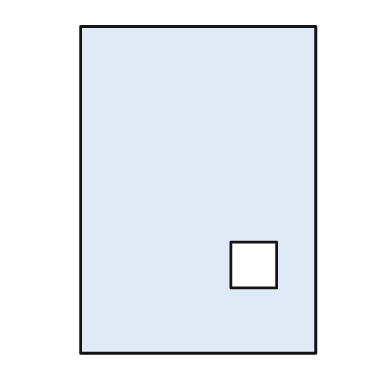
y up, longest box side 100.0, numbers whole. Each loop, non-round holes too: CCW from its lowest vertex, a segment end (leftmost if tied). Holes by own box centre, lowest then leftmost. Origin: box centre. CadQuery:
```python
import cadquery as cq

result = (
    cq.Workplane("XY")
    .moveTo(-36.0, -50.0)
    .lineTo(36.0, -50.0)
    .lineTo(36.0, 50.0)
    .lineTo(-36.0, 50.0)
    .close()
    .moveTo(10.0, -30.0)
    .lineTo(24.0, -30.0)
    .lineTo(24.0, -16.0)
    .lineTo(10.0, -16.0)
    .close()
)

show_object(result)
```